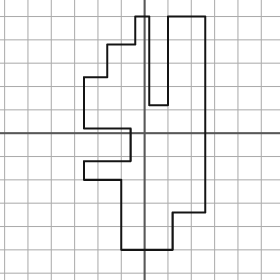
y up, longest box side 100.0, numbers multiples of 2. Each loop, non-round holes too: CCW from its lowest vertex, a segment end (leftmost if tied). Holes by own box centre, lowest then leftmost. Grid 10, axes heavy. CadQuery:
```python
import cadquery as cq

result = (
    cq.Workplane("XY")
    .moveTo(-10.0, -50.0)
    .lineTo(12.0, -50.0)
    .lineTo(12.0, -34.0)
    .lineTo(26.0, -34.0)
    .lineTo(26.0, 50.0)
    .lineTo(10.0, 50.0)
    .lineTo(10.0, 12.0)
    .lineTo(2.0, 12.0)
    .lineTo(2.0, 50.0)
    .lineTo(-4.0, 50.0)
    .lineTo(-4.0, 38.0)
    .lineTo(-16.0, 38.0)
    .lineTo(-16.0, 24.0)
    .lineTo(-26.0, 24.0)
    .lineTo(-26.0, 2.0)
    .lineTo(-6.0, 2.0)
    .lineTo(-6.0, -12.0)
    .lineTo(-26.0, -12.0)
    .lineTo(-26.0, -20.0)
    .lineTo(-10.0, -20.0)
    .close()
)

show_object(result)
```